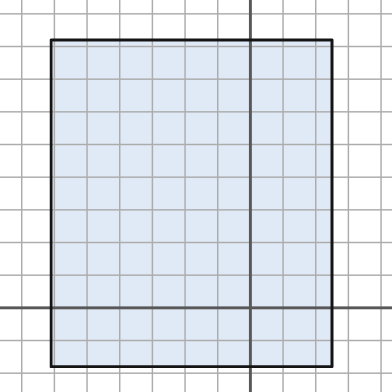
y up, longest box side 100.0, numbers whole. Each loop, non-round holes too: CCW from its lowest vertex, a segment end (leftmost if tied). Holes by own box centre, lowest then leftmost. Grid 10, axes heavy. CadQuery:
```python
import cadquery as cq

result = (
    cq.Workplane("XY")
    .moveTo(-61.0, -18.0)
    .lineTo(25.0, -18.0)
    .lineTo(25.0, 82.0)
    .lineTo(-61.0, 82.0)
    .close()
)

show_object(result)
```